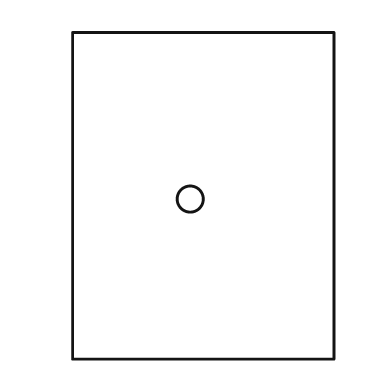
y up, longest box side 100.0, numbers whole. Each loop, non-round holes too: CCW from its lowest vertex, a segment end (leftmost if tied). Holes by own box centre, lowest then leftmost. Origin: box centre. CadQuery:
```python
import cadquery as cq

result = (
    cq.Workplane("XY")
    .moveTo(-40.0, -50.0)
    .lineTo(40.0, -50.0)
    .lineTo(40.0, 50.0)
    .lineTo(-40.0, 50.0)
    .close()
    .moveTo(-4.0, -1.0)
    .circle(4.0)
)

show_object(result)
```